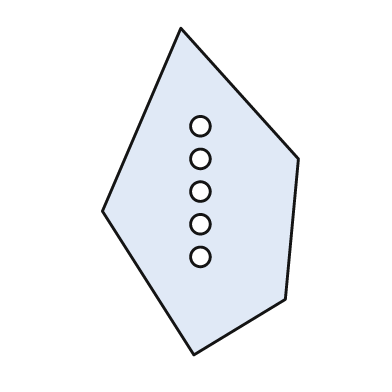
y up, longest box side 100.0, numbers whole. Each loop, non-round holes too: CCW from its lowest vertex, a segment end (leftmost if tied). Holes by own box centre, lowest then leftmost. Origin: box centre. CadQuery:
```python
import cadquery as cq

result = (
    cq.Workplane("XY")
    .moveTo(-2.0, -50.0)
    .lineTo(26.0, -33.0)
    .lineTo(30.0, 10.0)
    .lineTo(-6.0, 50.0)
    .lineTo(-30.0, -6.0)
    .close()
    .moveTo(0.0, -20.0)
    .circle(3.0)
    .moveTo(0.0, -10.0)
    .circle(3.0)
    .moveTo(0.0, 0.0)
    .circle(3.0)
    .moveTo(0.0, 10.0)
    .circle(3.0)
    .moveTo(0.0, 20.0)
    .circle(3.0)
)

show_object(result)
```